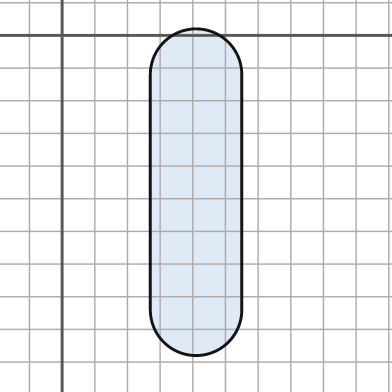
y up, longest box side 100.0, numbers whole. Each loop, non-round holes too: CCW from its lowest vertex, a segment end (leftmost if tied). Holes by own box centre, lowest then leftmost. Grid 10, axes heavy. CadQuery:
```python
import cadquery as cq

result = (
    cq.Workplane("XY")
    .moveTo(27.0, -84.0)
    .threePointArc((41.0, -98.0), (55.0, -84.0))
    .lineTo(55.0, -12.0)
    .threePointArc((41.0, 2.0), (27.0, -12.0))
    .close()
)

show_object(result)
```